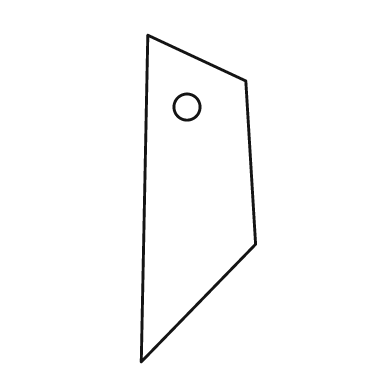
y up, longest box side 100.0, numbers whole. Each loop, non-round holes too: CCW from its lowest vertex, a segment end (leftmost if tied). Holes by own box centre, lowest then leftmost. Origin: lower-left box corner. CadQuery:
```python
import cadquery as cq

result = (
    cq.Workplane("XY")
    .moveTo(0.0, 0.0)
    .lineTo(35.0, 36.0)
    .lineTo(32.0, 86.0)
    .lineTo(2.0, 100.0)
    .close()
    .moveTo(14.0, 78.0)
    .circle(4.0)
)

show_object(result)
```